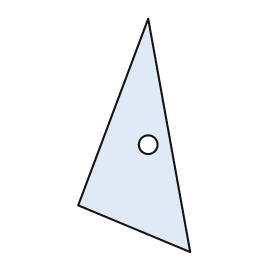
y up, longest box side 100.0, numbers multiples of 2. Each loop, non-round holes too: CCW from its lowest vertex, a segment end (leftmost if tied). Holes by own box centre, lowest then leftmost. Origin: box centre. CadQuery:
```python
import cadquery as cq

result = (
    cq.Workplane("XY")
    .moveTo(24.0, -50.0)
    .lineTo(6.0, 50.0)
    .lineTo(-24.0, -30.0)
    .close()
    .moveTo(6.0, -4.0)
    .circle(4.0)
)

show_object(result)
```